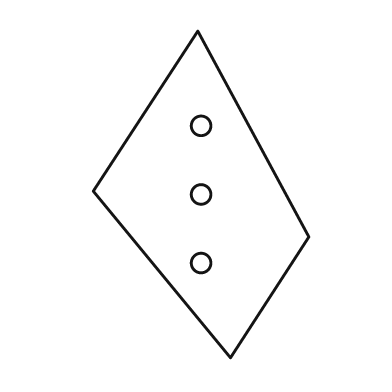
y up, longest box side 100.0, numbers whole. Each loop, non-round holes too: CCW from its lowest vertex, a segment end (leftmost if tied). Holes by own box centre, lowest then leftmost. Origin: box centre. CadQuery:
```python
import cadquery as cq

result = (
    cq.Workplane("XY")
    .moveTo(9.0, -50.0)
    .lineTo(33.0, -13.0)
    .lineTo(-1.0, 50.0)
    .lineTo(-33.0, 1.0)
    .close()
    .moveTo(0.0, -21.0)
    .circle(3.0)
    .moveTo(0.0, 0.0)
    .circle(3.0)
    .moveTo(0.0, 21.0)
    .circle(3.0)
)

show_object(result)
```